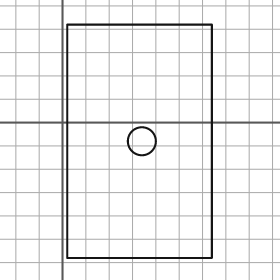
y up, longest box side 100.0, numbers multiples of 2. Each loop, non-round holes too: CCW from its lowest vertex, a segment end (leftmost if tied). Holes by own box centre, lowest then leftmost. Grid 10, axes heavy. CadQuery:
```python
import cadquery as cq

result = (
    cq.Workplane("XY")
    .moveTo(2.0, -58.0)
    .lineTo(64.0, -58.0)
    .lineTo(64.0, 42.0)
    .lineTo(2.0, 42.0)
    .close()
    .moveTo(34.0, -8.0)
    .circle(6.0)
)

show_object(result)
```